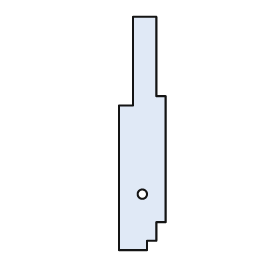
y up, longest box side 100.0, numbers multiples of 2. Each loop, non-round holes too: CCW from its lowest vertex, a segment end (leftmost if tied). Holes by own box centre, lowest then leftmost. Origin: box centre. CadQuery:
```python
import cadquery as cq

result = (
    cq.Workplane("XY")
    .moveTo(-10.0, -50.0)
    .lineTo(2.0, -50.0)
    .lineTo(2.0, -46.0)
    .lineTo(6.0, -46.0)
    .lineTo(6.0, -38.0)
    .lineTo(10.0, -38.0)
    .lineTo(10.0, 16.0)
    .lineTo(6.0, 16.0)
    .lineTo(6.0, 50.0)
    .lineTo(-4.0, 50.0)
    .lineTo(-4.0, 12.0)
    .lineTo(-10.0, 12.0)
    .close()
    .moveTo(0.0, -26.0)
    .circle(2.0)
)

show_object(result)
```